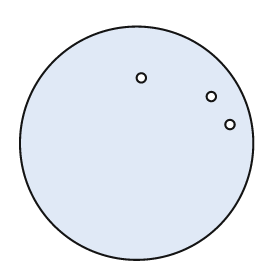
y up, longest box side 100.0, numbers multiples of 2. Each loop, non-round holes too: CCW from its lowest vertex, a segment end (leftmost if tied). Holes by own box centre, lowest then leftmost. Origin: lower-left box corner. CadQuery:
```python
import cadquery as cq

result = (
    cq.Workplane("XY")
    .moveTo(50.0, 50.0)
    .circle(50.0)
    .moveTo(90.0, 58.0)
    .circle(2.0)
    .moveTo(82.0, 70.0)
    .circle(2.0)
    .moveTo(52.0, 78.0)
    .circle(2.0)
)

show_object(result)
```